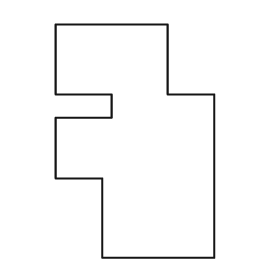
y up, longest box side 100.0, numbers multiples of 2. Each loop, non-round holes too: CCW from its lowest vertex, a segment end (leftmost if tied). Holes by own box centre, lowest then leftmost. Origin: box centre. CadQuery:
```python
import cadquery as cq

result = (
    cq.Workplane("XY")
    .moveTo(-14.0, -50.0)
    .lineTo(34.0, -50.0)
    .lineTo(34.0, 20.0)
    .lineTo(14.0, 20.0)
    .lineTo(14.0, 50.0)
    .lineTo(-34.0, 50.0)
    .lineTo(-34.0, 20.0)
    .lineTo(-10.0, 20.0)
    .lineTo(-10.0, 10.0)
    .lineTo(-34.0, 10.0)
    .lineTo(-34.0, -16.0)
    .lineTo(-14.0, -16.0)
    .close()
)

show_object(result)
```